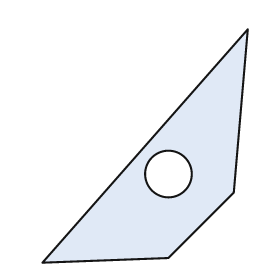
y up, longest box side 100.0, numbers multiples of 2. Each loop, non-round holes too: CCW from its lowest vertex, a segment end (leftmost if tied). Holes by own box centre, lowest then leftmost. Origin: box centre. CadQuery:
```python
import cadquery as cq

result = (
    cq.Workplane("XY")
    .moveTo(-44.0, -50.0)
    .lineTo(10.0, -48.0)
    .lineTo(38.0, -20.0)
    .lineTo(44.0, 50.0)
    .close()
    .moveTo(10.0, -12.0)
    .circle(10.0)
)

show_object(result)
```